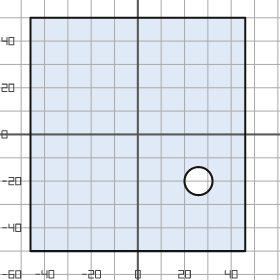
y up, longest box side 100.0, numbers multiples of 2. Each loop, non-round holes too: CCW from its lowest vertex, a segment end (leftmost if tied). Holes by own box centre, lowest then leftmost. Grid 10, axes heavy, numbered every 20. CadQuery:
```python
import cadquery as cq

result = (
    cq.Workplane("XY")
    .moveTo(-46.0, -50.0)
    .lineTo(46.0, -50.0)
    .lineTo(46.0, 50.0)
    .lineTo(-46.0, 50.0)
    .close()
    .moveTo(26.0, -20.0)
    .circle(6.0)
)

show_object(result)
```